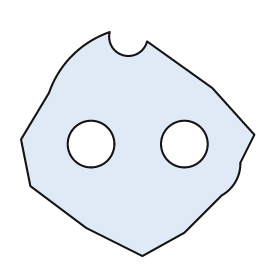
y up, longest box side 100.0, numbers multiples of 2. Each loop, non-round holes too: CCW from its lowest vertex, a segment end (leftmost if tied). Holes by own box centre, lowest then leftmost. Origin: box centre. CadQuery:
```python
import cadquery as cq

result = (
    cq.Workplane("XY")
    .moveTo(2.0, -48.0)
    .lineTo(20.0, -38.0)
    .lineTo(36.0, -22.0)
    .threePointArc((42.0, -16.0), (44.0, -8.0))
    .lineTo(50.0, 4.0)
    .lineTo(32.0, 24.0)
    .lineTo(4.0, 44.0)
    .threePointArc((-6.0, 38.0), (-12.0, 48.0))
    .threePointArc((-28.0, 38.0), (-38.0, 22.0))
    .lineTo(-50.0, 2.0)
    .lineTo(-46.0, -18.0)
    .lineTo(-22.0, -36.0)
    .close()
    .moveTo(-20.0, 0.0)
    .circle(10.0)
    .moveTo(20.0, 0.0)
    .circle(10.0)
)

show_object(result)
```